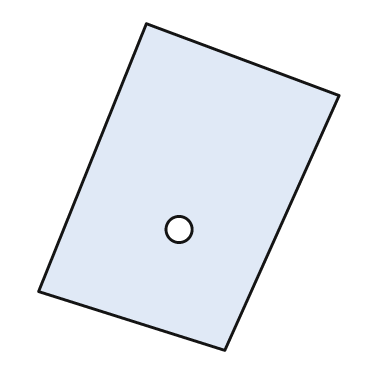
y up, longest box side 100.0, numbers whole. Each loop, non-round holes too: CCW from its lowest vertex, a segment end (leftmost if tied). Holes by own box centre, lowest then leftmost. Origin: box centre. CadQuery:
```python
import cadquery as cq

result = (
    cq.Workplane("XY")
    .moveTo(11.0, -50.0)
    .lineTo(46.0, 28.0)
    .lineTo(-13.0, 50.0)
    .lineTo(-46.0, -32.0)
    .close()
    .moveTo(-3.0, -13.0)
    .circle(4.0)
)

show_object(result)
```